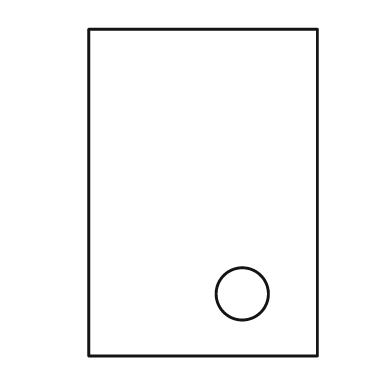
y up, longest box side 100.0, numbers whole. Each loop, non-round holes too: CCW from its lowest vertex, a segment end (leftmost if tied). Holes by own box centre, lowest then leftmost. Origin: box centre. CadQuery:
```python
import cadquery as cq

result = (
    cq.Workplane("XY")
    .moveTo(-35.0, -50.0)
    .lineTo(35.0, -50.0)
    .lineTo(35.0, 50.0)
    .lineTo(-35.0, 50.0)
    .close()
    .moveTo(12.0, -31.0)
    .circle(8.0)
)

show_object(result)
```